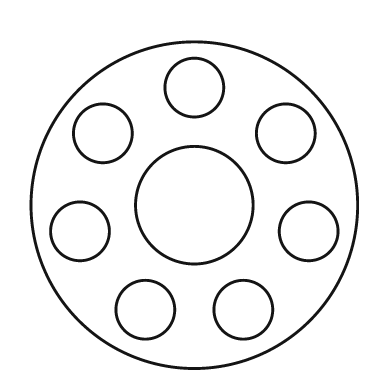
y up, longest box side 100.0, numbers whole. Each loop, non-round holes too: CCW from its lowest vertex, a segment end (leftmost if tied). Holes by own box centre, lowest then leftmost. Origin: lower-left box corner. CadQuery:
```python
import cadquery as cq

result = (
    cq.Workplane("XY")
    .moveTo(50.0, 50.0)
    .circle(50.0)
    .moveTo(35.0, 18.0)
    .circle(9.0)
    .moveTo(65.0, 18.0)
    .circle(9.0)
    .moveTo(15.0, 42.0)
    .circle(9.0)
    .moveTo(85.0, 42.0)
    .circle(9.0)
    .moveTo(50.0, 50.0)
    .circle(18.0)
    .moveTo(22.0, 72.0)
    .circle(9.0)
    .moveTo(78.0, 72.0)
    .circle(9.0)
    .moveTo(50.0, 86.0)
    .circle(9.0)
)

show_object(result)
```